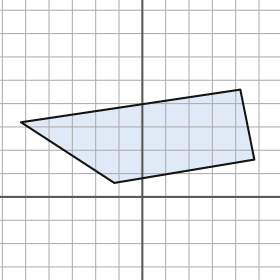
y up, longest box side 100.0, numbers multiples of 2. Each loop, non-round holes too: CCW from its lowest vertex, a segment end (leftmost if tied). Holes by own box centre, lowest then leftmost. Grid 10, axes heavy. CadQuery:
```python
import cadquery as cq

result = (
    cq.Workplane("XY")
    .moveTo(-12.0, 6.0)
    .lineTo(48.0, 16.0)
    .lineTo(42.0, 46.0)
    .lineTo(-52.0, 32.0)
    .close()
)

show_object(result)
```